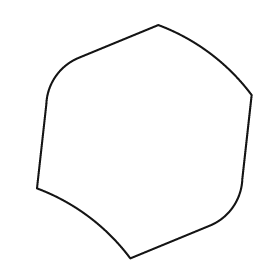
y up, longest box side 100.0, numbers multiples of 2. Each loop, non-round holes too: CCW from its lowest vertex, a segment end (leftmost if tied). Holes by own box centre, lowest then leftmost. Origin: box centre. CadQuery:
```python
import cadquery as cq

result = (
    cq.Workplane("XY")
    .moveTo(-6.0, -50.0)
    .lineTo(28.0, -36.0)
    .threePointArc((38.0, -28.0), (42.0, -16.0))
    .lineTo(46.0, 20.0)
    .threePointArc((28.0, 38.0), (6.0, 50.0))
    .lineTo(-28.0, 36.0)
    .threePointArc((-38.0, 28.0), (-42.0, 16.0))
    .lineTo(-46.0, -20.0)
    .threePointArc((-24.0, -32.0), (-6.0, -50.0))
    .close()
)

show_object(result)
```